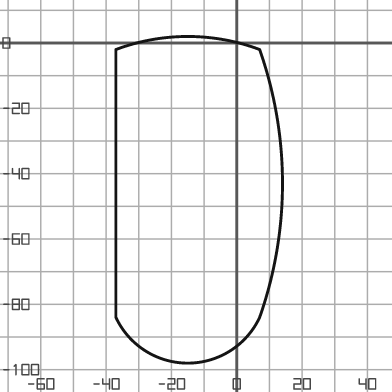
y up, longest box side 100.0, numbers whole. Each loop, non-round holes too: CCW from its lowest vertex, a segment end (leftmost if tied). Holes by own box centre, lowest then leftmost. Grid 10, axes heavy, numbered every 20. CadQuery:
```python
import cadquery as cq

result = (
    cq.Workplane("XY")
    .moveTo(-37.0, -84.0)
    .threePointArc((-15.0, -98.0), (7.0, -84.0))
    .threePointArc((14.0, -43.0), (7.0, -2.0))
    .threePointArc((-15.0, 2.0), (-37.0, -2.0))
    .close()
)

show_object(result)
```